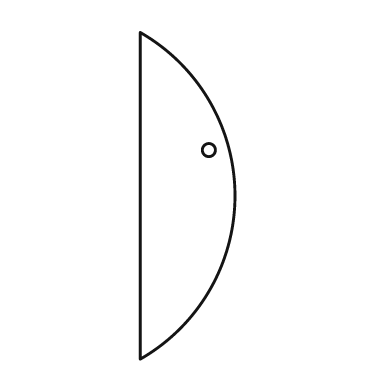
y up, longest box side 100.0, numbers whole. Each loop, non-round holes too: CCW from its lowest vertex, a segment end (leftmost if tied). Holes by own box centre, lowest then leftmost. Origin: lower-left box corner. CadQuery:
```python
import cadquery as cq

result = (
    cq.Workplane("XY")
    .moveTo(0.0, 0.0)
    .threePointArc((29.0, 50.0), (0.0, 100.0))
    .close()
    .moveTo(21.0, 64.0)
    .circle(2.0)
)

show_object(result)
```